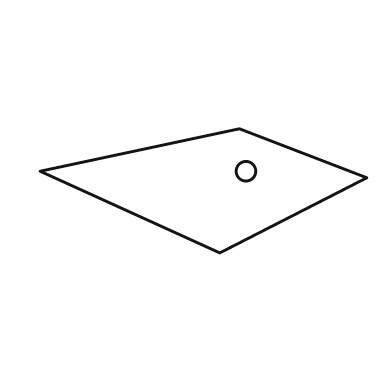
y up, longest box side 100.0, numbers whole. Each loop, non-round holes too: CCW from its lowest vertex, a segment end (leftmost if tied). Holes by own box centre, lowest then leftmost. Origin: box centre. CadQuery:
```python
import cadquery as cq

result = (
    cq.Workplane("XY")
    .moveTo(5.0, -19.0)
    .lineTo(50.0, 4.0)
    .lineTo(11.0, 19.0)
    .lineTo(-50.0, 6.0)
    .close()
    .moveTo(13.0, 6.0)
    .circle(3.0)
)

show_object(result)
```